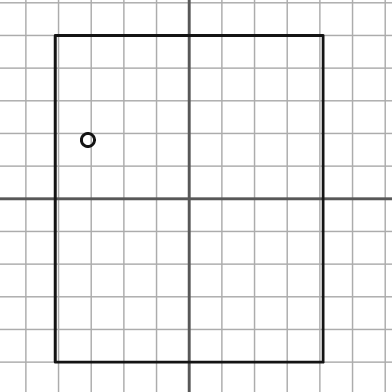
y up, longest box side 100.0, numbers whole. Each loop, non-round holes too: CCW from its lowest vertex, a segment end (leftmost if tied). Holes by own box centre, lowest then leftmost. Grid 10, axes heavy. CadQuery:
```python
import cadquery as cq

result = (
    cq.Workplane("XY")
    .moveTo(-41.0, -50.0)
    .lineTo(41.0, -50.0)
    .lineTo(41.0, 50.0)
    .lineTo(-41.0, 50.0)
    .close()
    .moveTo(-31.0, 18.0)
    .circle(2.0)
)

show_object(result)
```